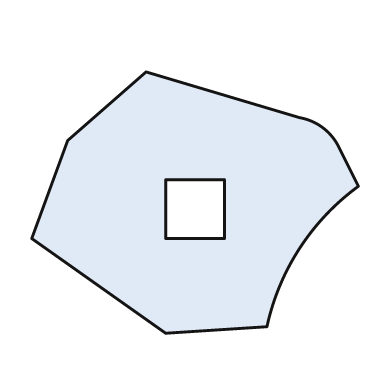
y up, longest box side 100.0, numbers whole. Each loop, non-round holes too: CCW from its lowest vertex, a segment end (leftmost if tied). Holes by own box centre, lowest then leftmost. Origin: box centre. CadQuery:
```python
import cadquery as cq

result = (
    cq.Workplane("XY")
    .moveTo(-9.0, -40.0)
    .lineTo(22.0, -38.0)
    .threePointArc((32.0, -14.0), (50.0, 5.0))
    .lineTo(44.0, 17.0)
    .threePointArc((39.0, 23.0), (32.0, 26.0))
    .lineTo(-15.0, 40.0)
    .lineTo(-39.0, 19.0)
    .lineTo(-50.0, -11.0)
    .close()
    .moveTo(-9.0, -11.0)
    .lineTo(9.0, -11.0)
    .lineTo(9.0, 7.0)
    .lineTo(-9.0, 7.0)
    .close()
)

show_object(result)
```